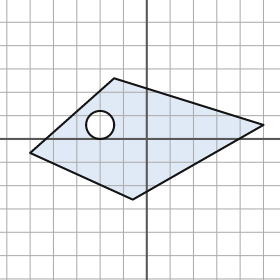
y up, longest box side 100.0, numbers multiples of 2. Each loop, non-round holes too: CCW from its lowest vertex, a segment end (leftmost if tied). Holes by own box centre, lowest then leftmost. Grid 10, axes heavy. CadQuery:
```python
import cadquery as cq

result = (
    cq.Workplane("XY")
    .moveTo(-6.0, -26.0)
    .lineTo(50.0, 6.0)
    .lineTo(-14.0, 26.0)
    .lineTo(-50.0, -6.0)
    .close()
    .moveTo(-20.0, 6.0)
    .circle(6.0)
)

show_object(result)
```